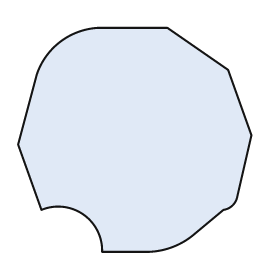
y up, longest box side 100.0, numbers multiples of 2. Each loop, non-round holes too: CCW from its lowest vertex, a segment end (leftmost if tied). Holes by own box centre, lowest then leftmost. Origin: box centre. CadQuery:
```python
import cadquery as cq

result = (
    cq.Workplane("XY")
    .moveTo(-14.0, -48.0)
    .lineTo(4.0, -48.0)
    .threePointArc((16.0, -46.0), (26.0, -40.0))
    .lineTo(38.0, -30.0)
    .threePointArc((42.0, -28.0), (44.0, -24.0))
    .lineTo(50.0, 2.0)
    .lineTo(40.0, 30.0)
    .lineTo(14.0, 48.0)
    .lineTo(-16.0, 48.0)
    .threePointArc((-32.0, 42.0), (-42.0, 28.0))
    .lineTo(-50.0, -2.0)
    .lineTo(-40.0, -30.0)
    .threePointArc((-22.0, -32.0), (-14.0, -48.0))
    .close()
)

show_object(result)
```